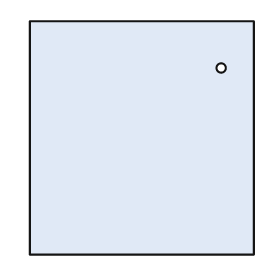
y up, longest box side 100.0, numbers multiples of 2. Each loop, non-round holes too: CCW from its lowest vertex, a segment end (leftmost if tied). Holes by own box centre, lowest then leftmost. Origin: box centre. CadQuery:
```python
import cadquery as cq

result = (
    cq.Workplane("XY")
    .moveTo(-48.0, -50.0)
    .lineTo(48.0, -50.0)
    .lineTo(48.0, 50.0)
    .lineTo(-48.0, 50.0)
    .close()
    .moveTo(34.0, 30.0)
    .circle(2.0)
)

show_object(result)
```